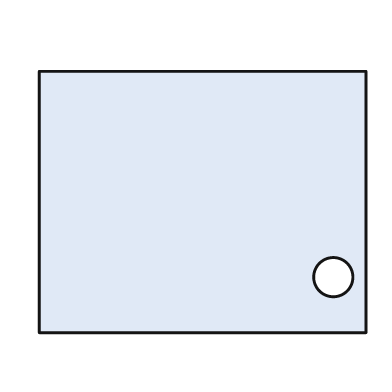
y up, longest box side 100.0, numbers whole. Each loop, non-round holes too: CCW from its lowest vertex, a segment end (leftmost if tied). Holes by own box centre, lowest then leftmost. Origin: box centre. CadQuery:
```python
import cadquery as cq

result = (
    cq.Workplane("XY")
    .moveTo(-50.0, -40.0)
    .lineTo(50.0, -40.0)
    .lineTo(50.0, 40.0)
    .lineTo(-50.0, 40.0)
    .close()
    .moveTo(40.0, -23.0)
    .circle(6.0)
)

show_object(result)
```